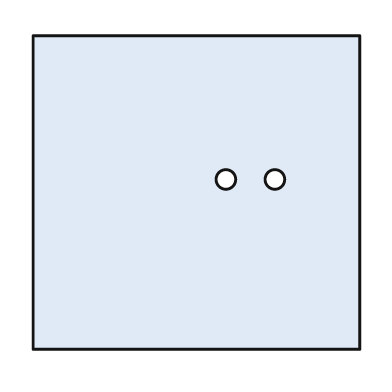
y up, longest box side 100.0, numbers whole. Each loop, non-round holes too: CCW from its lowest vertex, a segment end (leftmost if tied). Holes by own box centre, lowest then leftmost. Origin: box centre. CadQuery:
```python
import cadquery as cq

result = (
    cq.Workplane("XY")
    .moveTo(-50.0, -48.0)
    .lineTo(50.0, -48.0)
    .lineTo(50.0, 48.0)
    .lineTo(-50.0, 48.0)
    .close()
    .moveTo(9.0, 4.0)
    .circle(3.0)
    .moveTo(24.0, 4.0)
    .circle(3.0)
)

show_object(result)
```